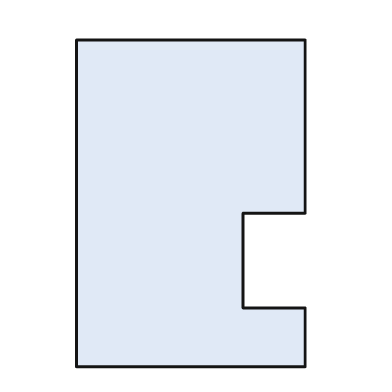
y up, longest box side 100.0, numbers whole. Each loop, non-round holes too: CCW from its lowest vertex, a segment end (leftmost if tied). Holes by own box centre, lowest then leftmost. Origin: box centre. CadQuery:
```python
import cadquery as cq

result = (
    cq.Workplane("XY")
    .moveTo(-35.0, -50.0)
    .lineTo(35.0, -50.0)
    .lineTo(35.0, -32.0)
    .lineTo(16.0, -32.0)
    .lineTo(16.0, -3.0)
    .lineTo(35.0, -3.0)
    .lineTo(35.0, 50.0)
    .lineTo(-35.0, 50.0)
    .close()
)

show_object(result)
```